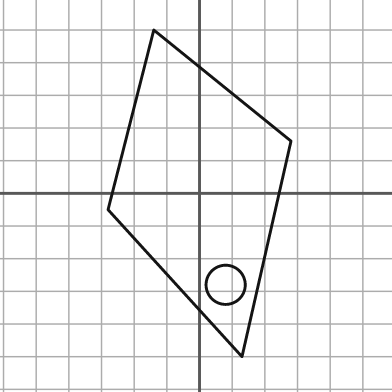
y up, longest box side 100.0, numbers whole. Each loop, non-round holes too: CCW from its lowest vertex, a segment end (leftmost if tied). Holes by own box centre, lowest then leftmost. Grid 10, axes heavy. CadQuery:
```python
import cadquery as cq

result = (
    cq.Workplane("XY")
    .moveTo(13.0, -50.0)
    .lineTo(28.0, 16.0)
    .lineTo(-14.0, 50.0)
    .lineTo(-28.0, -5.0)
    .close()
    .moveTo(8.0, -28.0)
    .circle(6.0)
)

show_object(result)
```